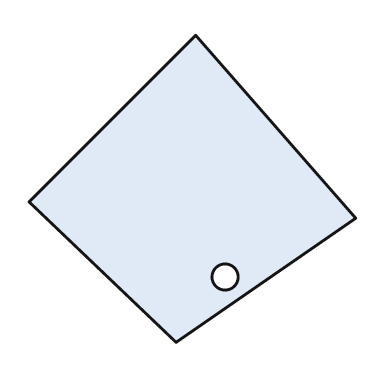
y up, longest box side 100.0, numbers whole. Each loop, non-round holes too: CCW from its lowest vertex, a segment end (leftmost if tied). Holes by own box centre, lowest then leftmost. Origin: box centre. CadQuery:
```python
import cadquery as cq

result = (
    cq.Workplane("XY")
    .moveTo(-5.0, -47.0)
    .lineTo(50.0, -9.0)
    .lineTo(1.0, 47.0)
    .lineTo(-50.0, -4.0)
    .close()
    .moveTo(10.0, -27.0)
    .circle(4.0)
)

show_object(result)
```